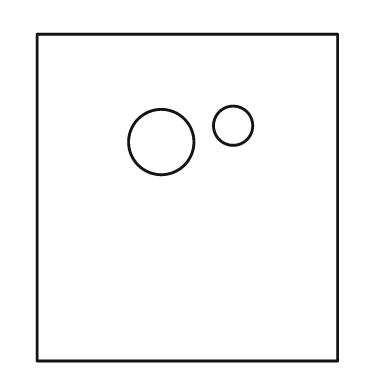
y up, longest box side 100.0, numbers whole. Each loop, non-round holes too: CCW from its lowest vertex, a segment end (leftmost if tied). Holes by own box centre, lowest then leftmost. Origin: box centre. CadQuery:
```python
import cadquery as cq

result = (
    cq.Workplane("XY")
    .moveTo(-46.0, -50.0)
    .lineTo(46.0, -50.0)
    .lineTo(46.0, 50.0)
    .lineTo(-46.0, 50.0)
    .close()
    .moveTo(-8.0, 17.0)
    .circle(10.0)
    .moveTo(14.0, 22.0)
    .circle(6.0)
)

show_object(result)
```